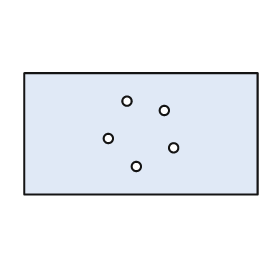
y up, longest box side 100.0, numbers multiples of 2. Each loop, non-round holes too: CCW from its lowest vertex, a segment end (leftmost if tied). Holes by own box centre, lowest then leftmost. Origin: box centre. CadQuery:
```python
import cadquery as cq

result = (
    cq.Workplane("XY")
    .moveTo(-50.0, -26.0)
    .lineTo(50.0, -26.0)
    .lineTo(50.0, 26.0)
    .lineTo(-50.0, 26.0)
    .close()
    .moveTo(-2.0, -14.0)
    .circle(2.0)
    .moveTo(14.0, -6.0)
    .circle(2.0)
    .moveTo(-14.0, -2.0)
    .circle(2.0)
    .moveTo(10.0, 10.0)
    .circle(2.0)
    .moveTo(-6.0, 14.0)
    .circle(2.0)
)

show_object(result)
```